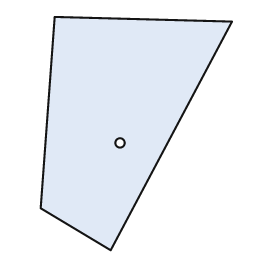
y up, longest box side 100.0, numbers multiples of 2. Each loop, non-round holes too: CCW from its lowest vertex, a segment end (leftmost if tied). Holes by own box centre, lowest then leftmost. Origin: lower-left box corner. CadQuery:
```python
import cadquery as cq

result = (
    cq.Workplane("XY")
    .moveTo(30.0, 0.0)
    .lineTo(82.0, 98.0)
    .lineTo(6.0, 100.0)
    .lineTo(0.0, 18.0)
    .close()
    .moveTo(34.0, 46.0)
    .circle(2.0)
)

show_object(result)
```